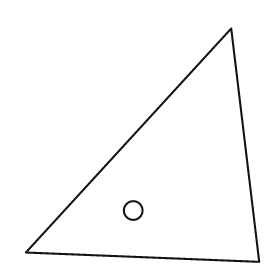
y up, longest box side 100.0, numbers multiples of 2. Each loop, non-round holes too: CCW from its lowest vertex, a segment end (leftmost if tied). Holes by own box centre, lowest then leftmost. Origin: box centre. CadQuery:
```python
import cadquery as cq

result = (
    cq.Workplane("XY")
    .moveTo(50.0, -50.0)
    .lineTo(38.0, 50.0)
    .lineTo(-50.0, -46.0)
    .close()
    .moveTo(-4.0, -28.0)
    .circle(4.0)
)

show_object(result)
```